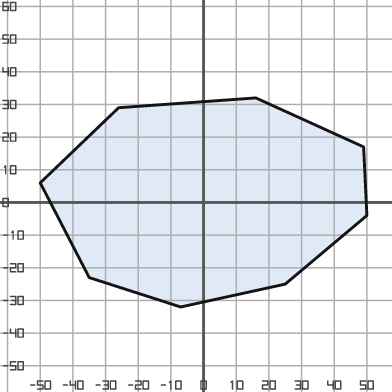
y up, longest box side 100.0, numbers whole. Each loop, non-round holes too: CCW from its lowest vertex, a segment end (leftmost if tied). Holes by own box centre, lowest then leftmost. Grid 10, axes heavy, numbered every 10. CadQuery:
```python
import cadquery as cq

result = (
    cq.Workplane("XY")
    .moveTo(-7.0, -32.0)
    .lineTo(25.0, -25.0)
    .lineTo(50.0, -4.0)
    .lineTo(49.0, 17.0)
    .lineTo(16.0, 32.0)
    .lineTo(-26.0, 29.0)
    .lineTo(-50.0, 6.0)
    .lineTo(-35.0, -23.0)
    .close()
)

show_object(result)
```